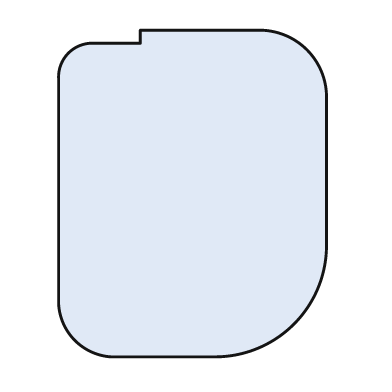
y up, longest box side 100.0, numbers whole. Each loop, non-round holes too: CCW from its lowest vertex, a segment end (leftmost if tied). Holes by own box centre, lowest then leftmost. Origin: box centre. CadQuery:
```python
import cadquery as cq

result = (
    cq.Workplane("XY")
    .moveTo(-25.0, -50.0)
    .lineTo(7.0, -50.0)
    .threePointArc((31.0, -40.0), (41.0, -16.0))
    .lineTo(41.0, 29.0)
    .threePointArc((35.0, 44.0), (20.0, 50.0))
    .lineTo(-16.0, 50.0)
    .lineTo(-16.0, 46.0)
    .lineTo(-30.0, 46.0)
    .threePointArc((-38.0, 43.0), (-41.0, 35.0))
    .lineTo(-41.0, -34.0)
    .threePointArc((-36.0, -45.0), (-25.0, -50.0))
    .close()
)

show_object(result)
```